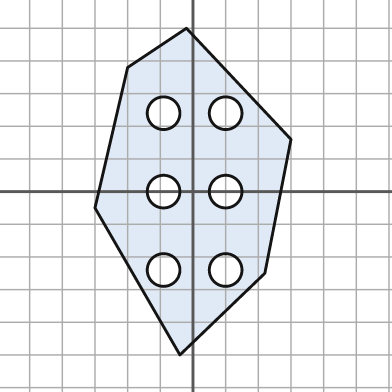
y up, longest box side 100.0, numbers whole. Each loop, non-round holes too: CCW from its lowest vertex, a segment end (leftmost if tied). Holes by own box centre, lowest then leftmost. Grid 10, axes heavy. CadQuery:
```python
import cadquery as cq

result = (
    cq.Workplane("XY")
    .moveTo(-4.0, -50.0)
    .lineTo(22.0, -25.0)
    .lineTo(30.0, 16.0)
    .lineTo(-2.0, 50.0)
    .lineTo(-20.0, 38.0)
    .lineTo(-30.0, -5.0)
    .close()
    .moveTo(-9.0, -24.0)
    .circle(5.0)
    .moveTo(10.0, -24.0)
    .circle(5.0)
    .moveTo(-9.0, 0.0)
    .circle(5.0)
    .moveTo(10.0, 0.0)
    .circle(5.0)
    .moveTo(-9.0, 24.0)
    .circle(5.0)
    .moveTo(10.0, 24.0)
    .circle(5.0)
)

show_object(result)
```